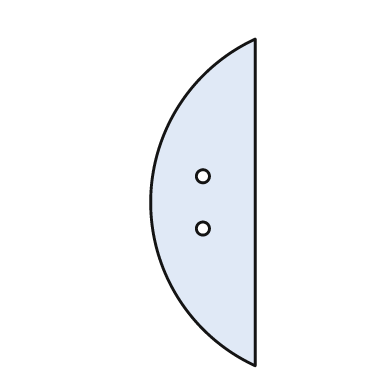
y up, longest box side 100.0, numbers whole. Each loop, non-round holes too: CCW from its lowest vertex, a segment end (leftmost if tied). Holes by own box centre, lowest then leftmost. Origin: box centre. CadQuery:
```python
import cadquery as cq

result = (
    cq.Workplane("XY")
    .moveTo(16.0, -50.0)
    .lineTo(16.0, 50.0)
    .threePointArc((-16.0, 0.0), (16.0, -50.0))
    .close()
    .moveTo(0.0, -8.0)
    .circle(2.0)
    .moveTo(0.0, 8.0)
    .circle(2.0)
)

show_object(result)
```